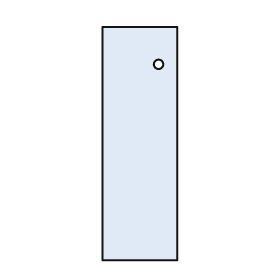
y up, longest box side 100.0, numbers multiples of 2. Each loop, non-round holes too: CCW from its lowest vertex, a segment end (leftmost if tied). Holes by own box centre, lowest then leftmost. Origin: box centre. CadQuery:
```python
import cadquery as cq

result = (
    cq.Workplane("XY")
    .moveTo(-16.0, -50.0)
    .lineTo(16.0, -50.0)
    .lineTo(16.0, 50.0)
    .lineTo(-16.0, 50.0)
    .close()
    .moveTo(8.0, 34.0)
    .circle(2.0)
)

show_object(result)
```